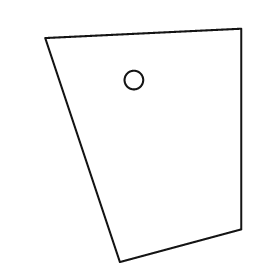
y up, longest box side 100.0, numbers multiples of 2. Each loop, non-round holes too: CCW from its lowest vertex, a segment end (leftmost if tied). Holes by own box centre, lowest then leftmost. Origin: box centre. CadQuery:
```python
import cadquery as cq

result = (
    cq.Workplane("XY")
    .moveTo(-10.0, -50.0)
    .lineTo(42.0, -36.0)
    .lineTo(42.0, 50.0)
    .lineTo(-42.0, 46.0)
    .close()
    .moveTo(-4.0, 28.0)
    .circle(4.0)
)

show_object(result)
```